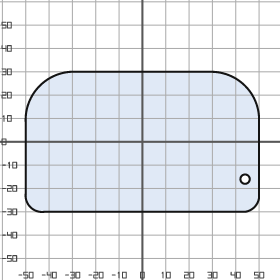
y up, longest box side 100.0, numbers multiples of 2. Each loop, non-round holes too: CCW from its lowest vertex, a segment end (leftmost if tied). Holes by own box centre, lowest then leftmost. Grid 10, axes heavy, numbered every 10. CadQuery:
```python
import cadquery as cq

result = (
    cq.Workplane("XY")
    .moveTo(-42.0, -30.0)
    .lineTo(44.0, -30.0)
    .threePointArc((48.0, -28.0), (50.0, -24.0))
    .lineTo(50.0, 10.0)
    .threePointArc((44.0, 24.0), (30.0, 30.0))
    .lineTo(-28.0, 30.0)
    .threePointArc((-44.0, 24.0), (-50.0, 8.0))
    .lineTo(-50.0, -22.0)
    .threePointArc((-48.0, -28.0), (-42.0, -30.0))
    .close()
    .moveTo(44.0, -16.0)
    .circle(2.0)
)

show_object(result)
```